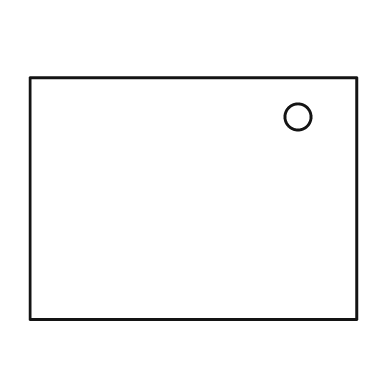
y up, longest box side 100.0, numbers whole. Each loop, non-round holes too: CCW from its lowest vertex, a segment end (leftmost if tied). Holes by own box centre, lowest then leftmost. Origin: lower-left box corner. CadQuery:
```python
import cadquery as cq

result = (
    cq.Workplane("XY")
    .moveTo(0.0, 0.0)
    .lineTo(100.0, 0.0)
    .lineTo(100.0, 74.0)
    .lineTo(0.0, 74.0)
    .close()
    .moveTo(82.0, 62.0)
    .circle(4.0)
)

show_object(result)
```